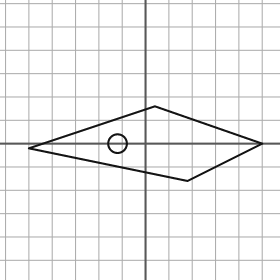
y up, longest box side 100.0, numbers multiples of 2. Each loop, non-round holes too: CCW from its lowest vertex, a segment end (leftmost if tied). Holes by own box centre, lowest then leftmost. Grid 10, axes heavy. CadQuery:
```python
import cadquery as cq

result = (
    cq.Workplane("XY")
    .moveTo(18.0, -16.0)
    .lineTo(50.0, 0.0)
    .lineTo(4.0, 16.0)
    .lineTo(-50.0, -2.0)
    .close()
    .moveTo(-12.0, 0.0)
    .circle(4.0)
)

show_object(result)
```